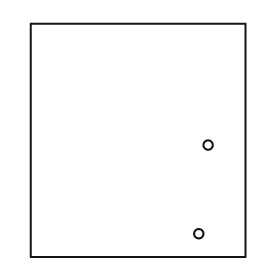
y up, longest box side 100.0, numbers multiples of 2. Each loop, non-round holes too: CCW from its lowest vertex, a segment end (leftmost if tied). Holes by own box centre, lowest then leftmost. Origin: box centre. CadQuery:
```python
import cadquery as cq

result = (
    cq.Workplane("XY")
    .moveTo(-46.0, -50.0)
    .lineTo(46.0, -50.0)
    .lineTo(46.0, 50.0)
    .lineTo(-46.0, 50.0)
    .close()
    .moveTo(26.0, -40.0)
    .circle(2.0)
    .moveTo(30.0, -2.0)
    .circle(2.0)
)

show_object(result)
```